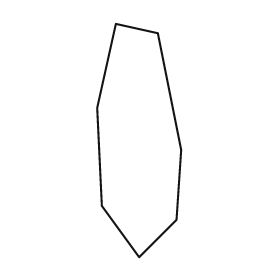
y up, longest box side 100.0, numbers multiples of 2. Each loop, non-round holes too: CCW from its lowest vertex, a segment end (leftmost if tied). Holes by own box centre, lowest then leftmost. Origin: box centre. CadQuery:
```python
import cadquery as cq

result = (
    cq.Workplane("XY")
    .moveTo(0.0, -50.0)
    .lineTo(16.0, -34.0)
    .lineTo(18.0, -4.0)
    .lineTo(8.0, 46.0)
    .lineTo(-10.0, 50.0)
    .lineTo(-18.0, 14.0)
    .lineTo(-16.0, -28.0)
    .close()
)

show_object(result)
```